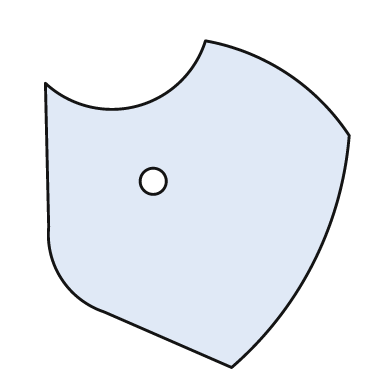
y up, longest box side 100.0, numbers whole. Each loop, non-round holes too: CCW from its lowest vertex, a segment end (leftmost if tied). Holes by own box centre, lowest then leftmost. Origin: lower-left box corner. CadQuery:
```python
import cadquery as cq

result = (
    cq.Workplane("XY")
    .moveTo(57.0, 0.0)
    .threePointArc((82.0, 32.0), (93.0, 71.0))
    .threePointArc((74.0, 90.0), (49.0, 100.0))
    .threePointArc((28.0, 80.0), (0.0, 87.0))
    .lineTo(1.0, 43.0)
    .threePointArc((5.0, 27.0), (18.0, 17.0))
    .close()
    .moveTo(33.0, 57.0)
    .circle(4.0)
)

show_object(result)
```